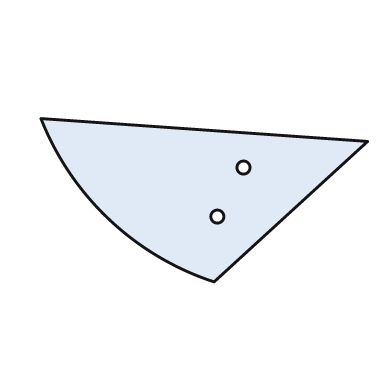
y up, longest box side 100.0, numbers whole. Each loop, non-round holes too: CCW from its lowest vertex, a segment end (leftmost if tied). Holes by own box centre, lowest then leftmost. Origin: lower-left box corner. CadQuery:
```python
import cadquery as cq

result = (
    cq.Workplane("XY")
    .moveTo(53.0, 0.0)
    .lineTo(100.0, 43.0)
    .lineTo(0.0, 50.0)
    .threePointArc((21.0, 19.0), (53.0, 0.0))
    .close()
    .moveTo(54.0, 20.0)
    .circle(2.0)
    .moveTo(62.0, 35.0)
    .circle(2.0)
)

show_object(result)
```